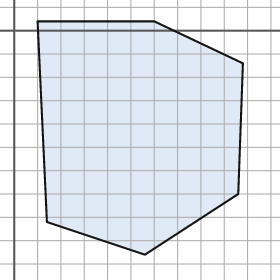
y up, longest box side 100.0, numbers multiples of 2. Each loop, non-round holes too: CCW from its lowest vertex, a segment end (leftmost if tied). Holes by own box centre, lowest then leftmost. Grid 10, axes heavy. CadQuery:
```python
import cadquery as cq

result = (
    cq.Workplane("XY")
    .moveTo(56.0, -96.0)
    .lineTo(96.0, -70.0)
    .lineTo(98.0, -14.0)
    .lineTo(60.0, 4.0)
    .lineTo(10.0, 4.0)
    .lineTo(14.0, -82.0)
    .close()
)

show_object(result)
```